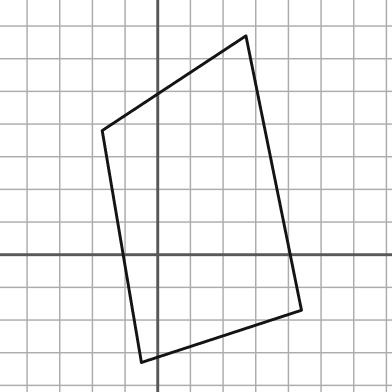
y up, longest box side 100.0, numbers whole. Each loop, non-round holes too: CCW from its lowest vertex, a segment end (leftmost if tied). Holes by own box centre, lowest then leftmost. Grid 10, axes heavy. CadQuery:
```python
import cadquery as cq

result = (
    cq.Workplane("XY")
    .moveTo(-5.0, -33.0)
    .lineTo(44.0, -17.0)
    .lineTo(27.0, 67.0)
    .lineTo(-17.0, 38.0)
    .close()
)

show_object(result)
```